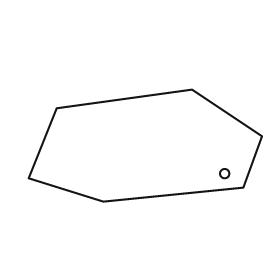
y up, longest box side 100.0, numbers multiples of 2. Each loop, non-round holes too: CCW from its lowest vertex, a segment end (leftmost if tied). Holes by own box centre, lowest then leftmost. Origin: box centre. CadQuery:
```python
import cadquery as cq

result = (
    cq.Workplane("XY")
    .moveTo(-18.0, -24.0)
    .lineTo(42.0, -18.0)
    .lineTo(50.0, 4.0)
    .lineTo(20.0, 24.0)
    .lineTo(-38.0, 16.0)
    .lineTo(-50.0, -14.0)
    .close()
    .moveTo(34.0, -12.0)
    .circle(2.0)
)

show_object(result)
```